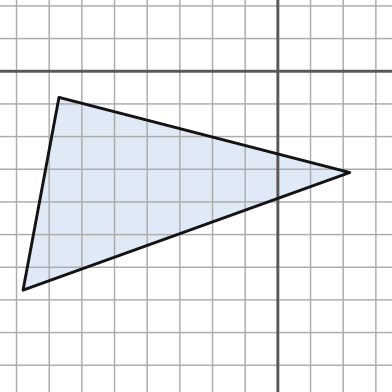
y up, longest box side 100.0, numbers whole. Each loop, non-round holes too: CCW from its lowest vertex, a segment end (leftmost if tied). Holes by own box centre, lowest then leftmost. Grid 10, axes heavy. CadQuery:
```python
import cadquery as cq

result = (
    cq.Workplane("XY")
    .moveTo(-78.0, -67.0)
    .lineTo(22.0, -31.0)
    .lineTo(-67.0, -8.0)
    .close()
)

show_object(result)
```